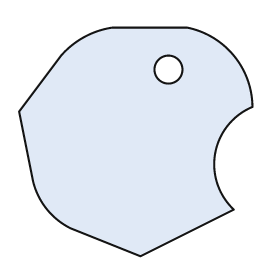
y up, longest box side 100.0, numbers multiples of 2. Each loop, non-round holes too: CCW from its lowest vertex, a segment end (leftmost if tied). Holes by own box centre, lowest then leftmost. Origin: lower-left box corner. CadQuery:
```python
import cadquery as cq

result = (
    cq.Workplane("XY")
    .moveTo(52.0, 0.0)
    .lineTo(92.0, 20.0)
    .threePointArc((84.0, 44.0), (100.0, 64.0))
    .threePointArc((92.0, 86.0), (72.0, 98.0))
    .lineTo(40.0, 98.0)
    .threePointArc((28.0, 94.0), (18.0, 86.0))
    .lineTo(0.0, 62.0)
    .lineTo(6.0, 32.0)
    .threePointArc((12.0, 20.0), (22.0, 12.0))
    .close()
    .moveTo(64.0, 80.0)
    .circle(6.0)
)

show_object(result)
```